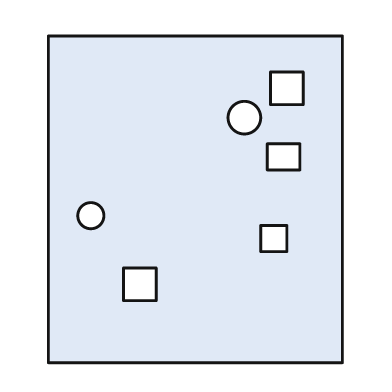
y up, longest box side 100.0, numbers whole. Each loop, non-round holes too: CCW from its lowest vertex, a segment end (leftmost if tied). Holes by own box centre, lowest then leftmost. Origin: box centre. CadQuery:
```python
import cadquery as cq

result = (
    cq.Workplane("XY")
    .moveTo(-45.0, -50.0)
    .lineTo(45.0, -50.0)
    .lineTo(45.0, 50.0)
    .lineTo(-45.0, 50.0)
    .close()
    .moveTo(-22.0, -31.0)
    .lineTo(-12.0, -31.0)
    .lineTo(-12.0, -21.0)
    .lineTo(-22.0, -21.0)
    .close()
    .moveTo(20.0, -16.0)
    .lineTo(28.0, -16.0)
    .lineTo(28.0, -8.0)
    .lineTo(20.0, -8.0)
    .close()
    .moveTo(-32.0, -5.0)
    .circle(4.0)
    .moveTo(22.0, 9.0)
    .lineTo(32.0, 9.0)
    .lineTo(32.0, 17.0)
    .lineTo(22.0, 17.0)
    .close()
    .moveTo(15.0, 25.0)
    .circle(5.0)
    .moveTo(23.0, 29.0)
    .lineTo(33.0, 29.0)
    .lineTo(33.0, 39.0)
    .lineTo(23.0, 39.0)
    .close()
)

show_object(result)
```